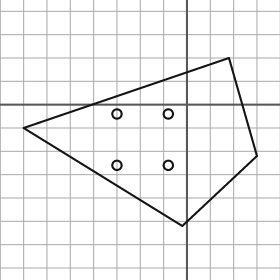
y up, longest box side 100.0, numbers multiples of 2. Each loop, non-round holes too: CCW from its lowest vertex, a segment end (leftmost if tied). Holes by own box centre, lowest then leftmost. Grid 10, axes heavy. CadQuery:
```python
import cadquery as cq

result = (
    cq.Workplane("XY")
    .moveTo(-2.0, -52.0)
    .lineTo(30.0, -22.0)
    .lineTo(18.0, 20.0)
    .lineTo(-70.0, -10.0)
    .close()
    .moveTo(-30.0, -26.0)
    .circle(2.0)
    .moveTo(-8.0, -26.0)
    .circle(2.0)
    .moveTo(-30.0, -4.0)
    .circle(2.0)
    .moveTo(-8.0, -4.0)
    .circle(2.0)
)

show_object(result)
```